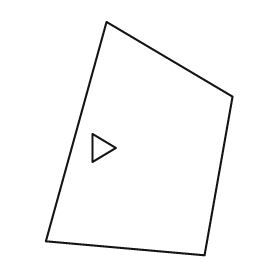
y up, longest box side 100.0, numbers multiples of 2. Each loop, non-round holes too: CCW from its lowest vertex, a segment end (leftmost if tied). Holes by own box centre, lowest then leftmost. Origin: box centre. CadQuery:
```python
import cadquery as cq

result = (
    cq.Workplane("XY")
    .moveTo(28.0, -50.0)
    .lineTo(40.0, 18.0)
    .lineTo(-14.0, 50.0)
    .lineTo(-40.0, -44.0)
    .close()
    .moveTo(-20.0, -10.0)
    .lineTo(-10.0, -4.0)
    .lineTo(-20.0, 2.0)
    .close()
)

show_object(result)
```